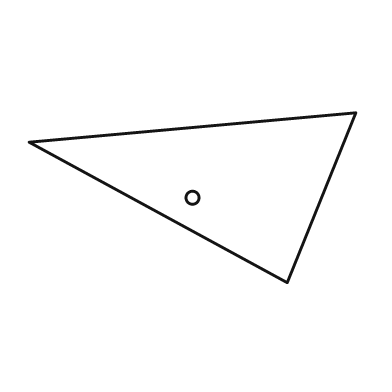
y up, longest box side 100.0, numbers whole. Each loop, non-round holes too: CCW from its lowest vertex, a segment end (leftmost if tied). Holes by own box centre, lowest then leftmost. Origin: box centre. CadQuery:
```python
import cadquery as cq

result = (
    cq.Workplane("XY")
    .moveTo(29.0, -26.0)
    .lineTo(50.0, 26.0)
    .lineTo(-50.0, 17.0)
    .close()
    .moveTo(0.0, 0.0)
    .circle(2.0)
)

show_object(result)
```